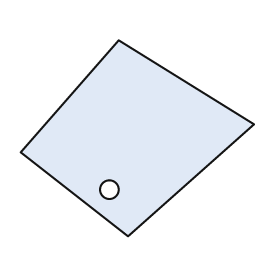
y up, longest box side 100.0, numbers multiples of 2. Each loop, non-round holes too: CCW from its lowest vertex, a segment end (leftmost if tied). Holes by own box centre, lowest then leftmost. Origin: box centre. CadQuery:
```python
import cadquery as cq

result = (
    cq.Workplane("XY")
    .moveTo(-4.0, -42.0)
    .lineTo(50.0, 6.0)
    .lineTo(-8.0, 42.0)
    .lineTo(-50.0, -6.0)
    .close()
    .moveTo(-12.0, -22.0)
    .circle(4.0)
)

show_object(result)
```